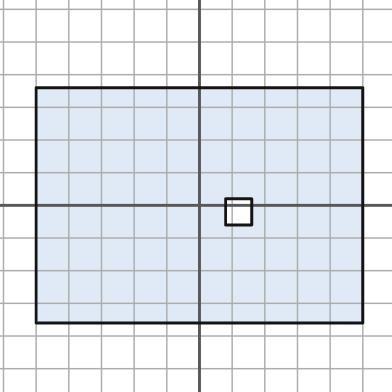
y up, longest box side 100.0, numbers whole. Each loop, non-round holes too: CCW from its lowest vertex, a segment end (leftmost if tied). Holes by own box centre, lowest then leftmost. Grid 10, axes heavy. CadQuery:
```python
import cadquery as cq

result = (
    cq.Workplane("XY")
    .moveTo(-50.0, -36.0)
    .lineTo(50.0, -36.0)
    .lineTo(50.0, 36.0)
    .lineTo(-50.0, 36.0)
    .close()
    .moveTo(8.0, -6.0)
    .lineTo(16.0, -6.0)
    .lineTo(16.0, 2.0)
    .lineTo(8.0, 2.0)
    .close()
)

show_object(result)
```